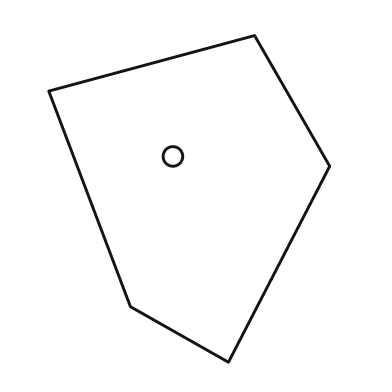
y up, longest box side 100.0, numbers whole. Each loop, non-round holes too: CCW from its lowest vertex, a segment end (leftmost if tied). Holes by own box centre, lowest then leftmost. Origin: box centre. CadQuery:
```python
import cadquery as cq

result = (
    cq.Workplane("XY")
    .moveTo(12.0, -50.0)
    .lineTo(43.0, 10.0)
    .lineTo(20.0, 50.0)
    .lineTo(-43.0, 33.0)
    .lineTo(-18.0, -33.0)
    .close()
    .moveTo(-5.0, 13.0)
    .circle(3.0)
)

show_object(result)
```